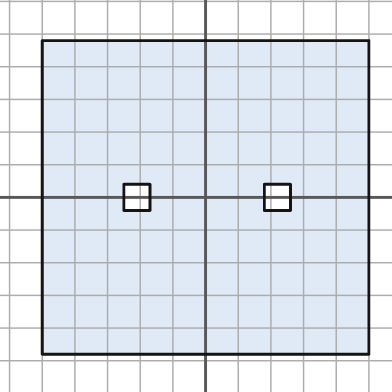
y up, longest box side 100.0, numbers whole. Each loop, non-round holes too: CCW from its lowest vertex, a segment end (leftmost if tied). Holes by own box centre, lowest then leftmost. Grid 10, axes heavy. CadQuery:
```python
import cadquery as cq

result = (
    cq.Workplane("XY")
    .moveTo(-50.0, -48.0)
    .lineTo(50.0, -48.0)
    .lineTo(50.0, 48.0)
    .lineTo(-50.0, 48.0)
    .close()
    .moveTo(-25.0, -4.0)
    .lineTo(-17.0, -4.0)
    .lineTo(-17.0, 4.0)
    .lineTo(-25.0, 4.0)
    .close()
    .moveTo(18.0, -4.0)
    .lineTo(26.0, -4.0)
    .lineTo(26.0, 4.0)
    .lineTo(18.0, 4.0)
    .close()
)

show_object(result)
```